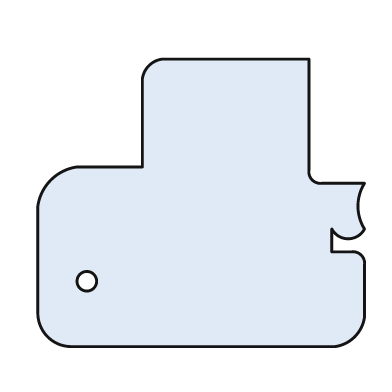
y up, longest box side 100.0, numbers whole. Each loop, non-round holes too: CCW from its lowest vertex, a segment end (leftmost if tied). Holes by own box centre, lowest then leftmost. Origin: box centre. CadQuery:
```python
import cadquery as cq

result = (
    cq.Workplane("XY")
    .moveTo(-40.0, -44.0)
    .lineTo(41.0, -44.0)
    .threePointArc((47.0, -41.0), (50.0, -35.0))
    .lineTo(50.0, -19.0)
    .threePointArc((49.0, -16.0), (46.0, -15.0))
    .lineTo(40.0, -15.0)
    .lineTo(40.0, -8.0)
    .threePointArc((45.0, -11.0), (50.0, -8.0))
    .threePointArc((48.0, -1.0), (50.0, 6.0))
    .lineTo(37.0, 6.0)
    .threePointArc((34.0, 7.0), (33.0, 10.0))
    .lineTo(33.0, 44.0)
    .lineTo(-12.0, 44.0)
    .threePointArc((-16.0, 42.0), (-18.0, 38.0))
    .lineTo(-18.0, 11.0)
    .lineTo(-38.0, 11.0)
    .threePointArc((-46.0, 7.0), (-50.0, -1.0))
    .lineTo(-50.0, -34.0)
    .threePointArc((-47.0, -41.0), (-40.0, -44.0))
    .close()
    .moveTo(-35.0, -24.0)
    .circle(3.0)
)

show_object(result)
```